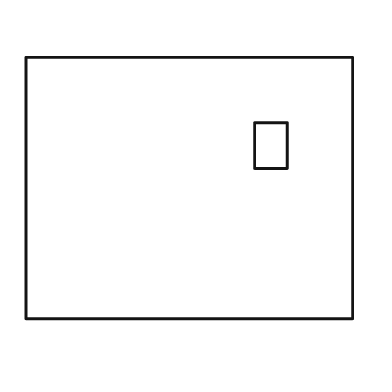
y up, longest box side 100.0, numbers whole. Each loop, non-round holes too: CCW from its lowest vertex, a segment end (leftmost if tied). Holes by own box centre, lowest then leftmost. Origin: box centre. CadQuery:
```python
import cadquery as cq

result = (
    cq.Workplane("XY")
    .moveTo(-50.0, -40.0)
    .lineTo(50.0, -40.0)
    .lineTo(50.0, 40.0)
    .lineTo(-50.0, 40.0)
    .close()
    .moveTo(20.0, 6.0)
    .lineTo(30.0, 6.0)
    .lineTo(30.0, 20.0)
    .lineTo(20.0, 20.0)
    .close()
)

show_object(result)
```